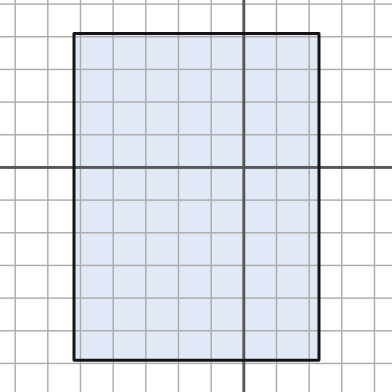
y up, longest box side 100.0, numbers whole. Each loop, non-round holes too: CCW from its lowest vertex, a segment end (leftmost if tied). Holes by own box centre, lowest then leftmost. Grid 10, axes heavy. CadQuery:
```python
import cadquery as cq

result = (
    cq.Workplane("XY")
    .moveTo(-52.0, -59.0)
    .lineTo(23.0, -59.0)
    .lineTo(23.0, 41.0)
    .lineTo(-52.0, 41.0)
    .close()
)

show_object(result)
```